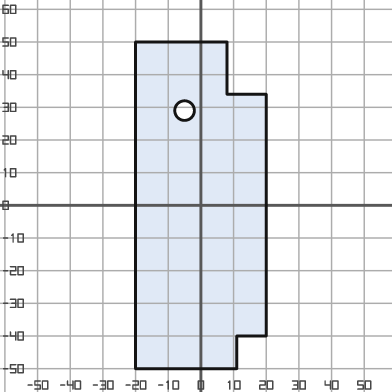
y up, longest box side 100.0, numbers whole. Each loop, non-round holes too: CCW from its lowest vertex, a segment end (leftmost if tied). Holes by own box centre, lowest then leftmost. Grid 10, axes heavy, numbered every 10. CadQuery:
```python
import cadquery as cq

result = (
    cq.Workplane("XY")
    .moveTo(-20.0, -50.0)
    .lineTo(11.0, -50.0)
    .lineTo(11.0, -40.0)
    .lineTo(20.0, -40.0)
    .lineTo(20.0, 34.0)
    .lineTo(8.0, 34.0)
    .lineTo(8.0, 50.0)
    .lineTo(-20.0, 50.0)
    .close()
    .moveTo(-5.0, 29.0)
    .circle(3.0)
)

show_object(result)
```